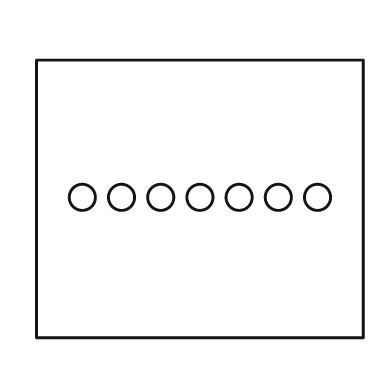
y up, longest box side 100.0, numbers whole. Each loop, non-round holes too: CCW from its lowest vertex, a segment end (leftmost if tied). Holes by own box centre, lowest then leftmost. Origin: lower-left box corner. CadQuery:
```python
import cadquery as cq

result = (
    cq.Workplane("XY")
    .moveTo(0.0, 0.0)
    .lineTo(100.0, 0.0)
    .lineTo(100.0, 85.0)
    .lineTo(0.0, 85.0)
    .close()
    .moveTo(14.0, 43.0)
    .circle(4.0)
    .moveTo(26.0, 43.0)
    .circle(4.0)
    .moveTo(38.0, 43.0)
    .circle(4.0)
    .moveTo(50.0, 43.0)
    .circle(4.0)
    .moveTo(62.0, 43.0)
    .circle(4.0)
    .moveTo(74.0, 43.0)
    .circle(4.0)
    .moveTo(86.0, 43.0)
    .circle(4.0)
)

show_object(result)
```